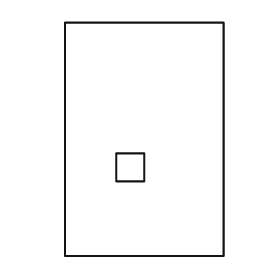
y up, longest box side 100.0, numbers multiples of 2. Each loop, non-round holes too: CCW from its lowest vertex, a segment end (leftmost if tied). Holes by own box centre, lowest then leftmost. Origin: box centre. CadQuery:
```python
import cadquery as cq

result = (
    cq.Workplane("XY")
    .moveTo(-34.0, -50.0)
    .lineTo(34.0, -50.0)
    .lineTo(34.0, 50.0)
    .lineTo(-34.0, 50.0)
    .close()
    .moveTo(-12.0, -18.0)
    .lineTo(0.0, -18.0)
    .lineTo(0.0, -6.0)
    .lineTo(-12.0, -6.0)
    .close()
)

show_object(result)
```